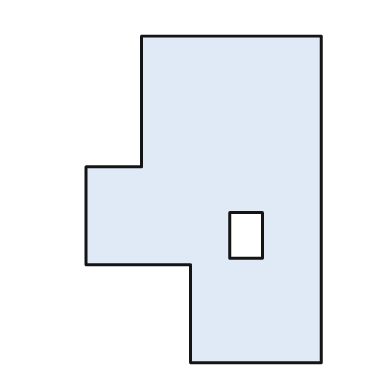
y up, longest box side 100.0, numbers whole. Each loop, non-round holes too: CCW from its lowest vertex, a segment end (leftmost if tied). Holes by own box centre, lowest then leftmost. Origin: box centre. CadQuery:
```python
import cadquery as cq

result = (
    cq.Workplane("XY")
    .moveTo(-4.0, -50.0)
    .lineTo(36.0, -50.0)
    .lineTo(36.0, 50.0)
    .lineTo(-19.0, 50.0)
    .lineTo(-19.0, 10.0)
    .lineTo(-36.0, 10.0)
    .lineTo(-36.0, -20.0)
    .lineTo(-4.0, -20.0)
    .close()
    .moveTo(8.0, -18.0)
    .lineTo(18.0, -18.0)
    .lineTo(18.0, -4.0)
    .lineTo(8.0, -4.0)
    .close()
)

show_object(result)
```